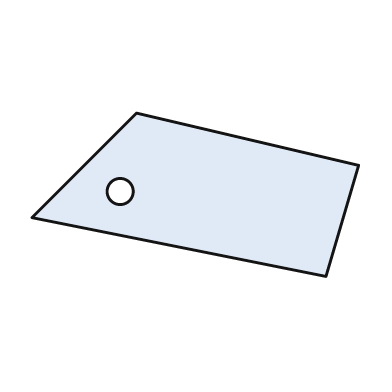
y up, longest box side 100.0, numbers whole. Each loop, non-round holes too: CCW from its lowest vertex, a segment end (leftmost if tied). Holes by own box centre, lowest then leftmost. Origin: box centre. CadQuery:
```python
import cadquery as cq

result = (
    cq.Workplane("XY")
    .moveTo(40.0, -25.0)
    .lineTo(50.0, 9.0)
    .lineTo(-18.0, 25.0)
    .lineTo(-50.0, -7.0)
    .close()
    .moveTo(-23.0, 1.0)
    .circle(4.0)
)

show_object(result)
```